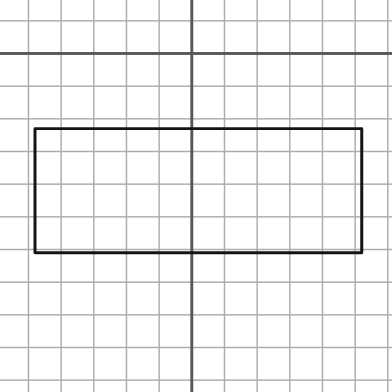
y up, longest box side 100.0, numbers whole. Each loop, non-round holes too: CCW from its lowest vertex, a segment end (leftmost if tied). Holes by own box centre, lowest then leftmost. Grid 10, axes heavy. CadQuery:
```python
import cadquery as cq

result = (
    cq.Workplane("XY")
    .moveTo(-48.0, -61.0)
    .lineTo(52.0, -61.0)
    .lineTo(52.0, -23.0)
    .lineTo(-48.0, -23.0)
    .close()
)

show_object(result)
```